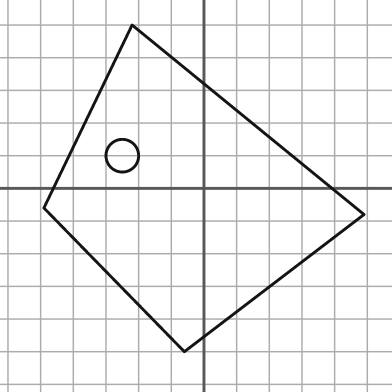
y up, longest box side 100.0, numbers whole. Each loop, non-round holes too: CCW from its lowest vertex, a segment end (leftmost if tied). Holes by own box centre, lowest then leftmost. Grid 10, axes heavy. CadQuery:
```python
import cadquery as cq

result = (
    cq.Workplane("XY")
    .moveTo(-6.0, -50.0)
    .lineTo(49.0, -8.0)
    .lineTo(-22.0, 50.0)
    .lineTo(-49.0, -6.0)
    .close()
    .moveTo(-25.0, 10.0)
    .circle(5.0)
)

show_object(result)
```